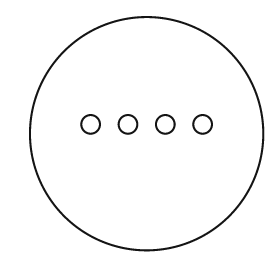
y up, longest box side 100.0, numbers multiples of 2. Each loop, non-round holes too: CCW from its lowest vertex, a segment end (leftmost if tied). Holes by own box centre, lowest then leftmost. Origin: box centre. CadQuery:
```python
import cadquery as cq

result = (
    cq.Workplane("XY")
    .moveTo(0.0, 0.0)
    .circle(50.0)
    .moveTo(-24.0, 4.0)
    .circle(4.0)
    .moveTo(-8.0, 4.0)
    .circle(4.0)
    .moveTo(8.0, 4.0)
    .circle(4.0)
    .moveTo(24.0, 4.0)
    .circle(4.0)
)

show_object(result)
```